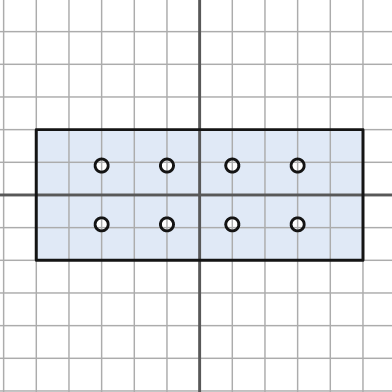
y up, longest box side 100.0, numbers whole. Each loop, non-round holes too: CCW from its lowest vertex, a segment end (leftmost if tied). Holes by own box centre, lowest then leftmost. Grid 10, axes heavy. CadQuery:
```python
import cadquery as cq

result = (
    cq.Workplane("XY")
    .moveTo(-50.0, -20.0)
    .lineTo(50.0, -20.0)
    .lineTo(50.0, 20.0)
    .lineTo(-50.0, 20.0)
    .close()
    .moveTo(-30.0, -9.0)
    .circle(2.0)
    .moveTo(-10.0, -9.0)
    .circle(2.0)
    .moveTo(10.0, -9.0)
    .circle(2.0)
    .moveTo(30.0, -9.0)
    .circle(2.0)
    .moveTo(-30.0, 9.0)
    .circle(2.0)
    .moveTo(-10.0, 9.0)
    .circle(2.0)
    .moveTo(10.0, 9.0)
    .circle(2.0)
    .moveTo(30.0, 9.0)
    .circle(2.0)
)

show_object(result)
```